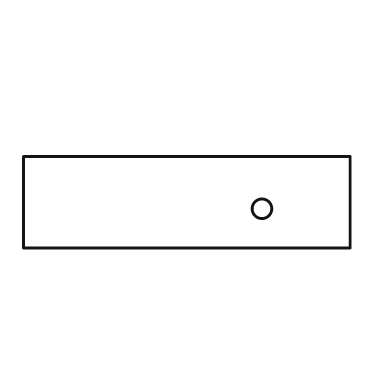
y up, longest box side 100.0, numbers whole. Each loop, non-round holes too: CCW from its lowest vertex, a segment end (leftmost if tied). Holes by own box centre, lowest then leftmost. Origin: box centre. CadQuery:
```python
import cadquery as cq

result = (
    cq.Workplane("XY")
    .moveTo(-50.0, -14.0)
    .lineTo(50.0, -14.0)
    .lineTo(50.0, 14.0)
    .lineTo(-50.0, 14.0)
    .close()
    .moveTo(23.0, -2.0)
    .circle(3.0)
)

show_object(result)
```